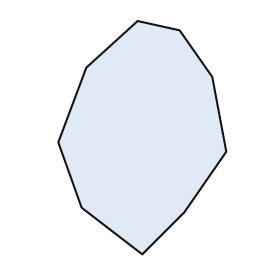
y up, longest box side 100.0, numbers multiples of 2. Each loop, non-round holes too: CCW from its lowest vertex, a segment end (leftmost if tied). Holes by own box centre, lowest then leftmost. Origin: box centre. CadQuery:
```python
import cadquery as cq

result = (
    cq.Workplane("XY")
    .moveTo(0.0, -50.0)
    .lineTo(18.0, -32.0)
    .lineTo(36.0, -6.0)
    .lineTo(30.0, 26.0)
    .lineTo(16.0, 46.0)
    .lineTo(-2.0, 50.0)
    .lineTo(-24.0, 30.0)
    .lineTo(-36.0, -2.0)
    .lineTo(-26.0, -30.0)
    .close()
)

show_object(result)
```